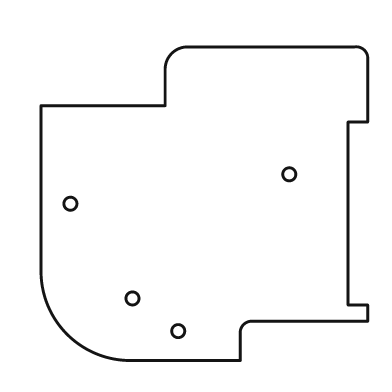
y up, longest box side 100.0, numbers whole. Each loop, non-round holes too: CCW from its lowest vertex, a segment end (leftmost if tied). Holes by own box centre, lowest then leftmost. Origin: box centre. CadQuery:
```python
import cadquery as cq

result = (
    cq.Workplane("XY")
    .moveTo(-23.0, -48.0)
    .lineTo(11.0, -48.0)
    .lineTo(11.0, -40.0)
    .threePointArc((12.0, -37.0), (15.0, -36.0))
    .lineTo(50.0, -36.0)
    .lineTo(50.0, -31.0)
    .lineTo(44.0, -31.0)
    .lineTo(44.0, 25.0)
    .lineTo(50.0, 25.0)
    .lineTo(50.0, 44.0)
    .threePointArc((49.0, 47.0), (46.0, 48.0))
    .lineTo(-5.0, 48.0)
    .threePointArc((-10.0, 46.0), (-12.0, 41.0))
    .lineTo(-12.0, 30.0)
    .lineTo(-50.0, 30.0)
    .lineTo(-50.0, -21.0)
    .threePointArc((-42.0, -40.0), (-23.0, -48.0))
    .close()
    .moveTo(-8.0, -39.0)
    .circle(2.0)
    .moveTo(-22.0, -29.0)
    .circle(2.0)
    .moveTo(-41.0, 0.0)
    .circle(2.0)
    .moveTo(26.0, 9.0)
    .circle(2.0)
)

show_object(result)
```